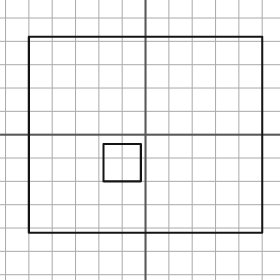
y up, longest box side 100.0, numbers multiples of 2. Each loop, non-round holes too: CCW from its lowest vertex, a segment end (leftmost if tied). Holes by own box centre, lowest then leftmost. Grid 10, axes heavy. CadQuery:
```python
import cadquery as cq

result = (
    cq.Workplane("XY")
    .moveTo(-50.0, -42.0)
    .lineTo(50.0, -42.0)
    .lineTo(50.0, 42.0)
    .lineTo(-50.0, 42.0)
    .close()
    .moveTo(-18.0, -20.0)
    .lineTo(-2.0, -20.0)
    .lineTo(-2.0, -4.0)
    .lineTo(-18.0, -4.0)
    .close()
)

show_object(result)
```